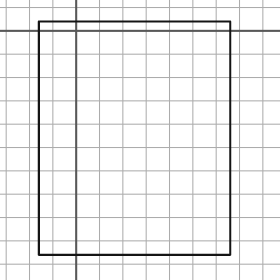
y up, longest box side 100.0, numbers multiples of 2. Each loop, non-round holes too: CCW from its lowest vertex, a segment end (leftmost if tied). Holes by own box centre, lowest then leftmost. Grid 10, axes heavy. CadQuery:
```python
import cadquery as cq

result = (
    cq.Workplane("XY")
    .moveTo(-16.0, -96.0)
    .lineTo(66.0, -96.0)
    .lineTo(66.0, 4.0)
    .lineTo(-16.0, 4.0)
    .close()
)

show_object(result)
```